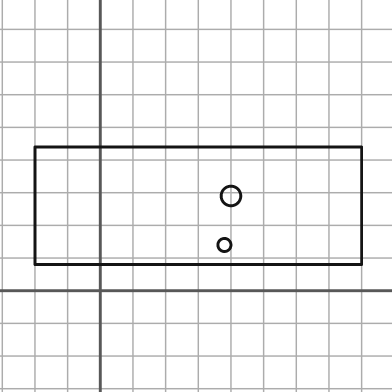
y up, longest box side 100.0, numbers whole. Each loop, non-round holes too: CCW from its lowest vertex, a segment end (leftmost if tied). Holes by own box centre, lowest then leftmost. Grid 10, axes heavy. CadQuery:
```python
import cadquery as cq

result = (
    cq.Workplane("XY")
    .moveTo(-20.0, 8.0)
    .lineTo(80.0, 8.0)
    .lineTo(80.0, 44.0)
    .lineTo(-20.0, 44.0)
    .close()
    .moveTo(38.0, 14.0)
    .circle(2.0)
    .moveTo(40.0, 29.0)
    .circle(3.0)
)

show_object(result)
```